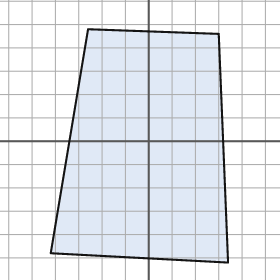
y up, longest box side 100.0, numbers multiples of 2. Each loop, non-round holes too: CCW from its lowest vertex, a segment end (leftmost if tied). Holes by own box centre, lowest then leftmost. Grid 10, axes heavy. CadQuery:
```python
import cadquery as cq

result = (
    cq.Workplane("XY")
    .moveTo(34.0, -52.0)
    .lineTo(30.0, 46.0)
    .lineTo(-26.0, 48.0)
    .lineTo(-42.0, -48.0)
    .close()
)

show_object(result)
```